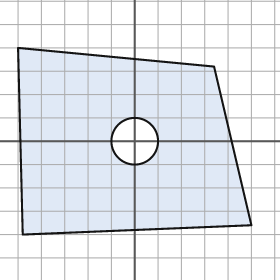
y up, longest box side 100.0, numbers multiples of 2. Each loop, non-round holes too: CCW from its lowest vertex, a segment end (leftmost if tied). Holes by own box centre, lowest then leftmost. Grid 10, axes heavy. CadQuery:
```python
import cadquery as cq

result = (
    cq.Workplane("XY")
    .moveTo(-48.0, -40.0)
    .lineTo(50.0, -36.0)
    .lineTo(34.0, 32.0)
    .lineTo(-50.0, 40.0)
    .close()
    .moveTo(0.0, 0.0)
    .circle(10.0)
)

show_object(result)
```